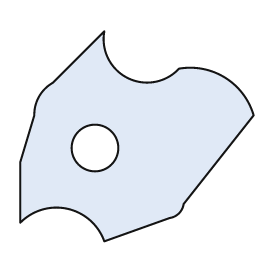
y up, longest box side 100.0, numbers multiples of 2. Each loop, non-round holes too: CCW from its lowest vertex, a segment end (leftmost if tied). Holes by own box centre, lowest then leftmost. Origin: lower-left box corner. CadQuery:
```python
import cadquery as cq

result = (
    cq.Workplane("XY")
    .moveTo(36.0, 0.0)
    .lineTo(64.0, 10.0)
    .threePointArc((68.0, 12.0), (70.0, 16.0))
    .lineTo(100.0, 54.0)
    .threePointArc((88.0, 70.0), (68.0, 74.0))
    .threePointArc((46.0, 70.0), (36.0, 90.0))
    .lineTo(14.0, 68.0)
    .threePointArc((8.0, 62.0), (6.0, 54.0))
    .lineTo(0.0, 34.0)
    .lineTo(0.0, 8.0)
    .threePointArc((20.0, 14.0), (36.0, 0.0))
    .close()
    .moveTo(32.0, 40.0)
    .circle(10.0)
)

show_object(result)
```